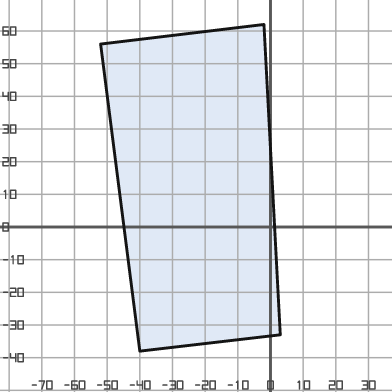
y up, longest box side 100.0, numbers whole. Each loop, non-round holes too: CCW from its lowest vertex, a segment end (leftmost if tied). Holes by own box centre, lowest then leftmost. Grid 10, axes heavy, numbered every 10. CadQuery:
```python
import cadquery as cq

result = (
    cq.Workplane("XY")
    .moveTo(-40.0, -38.0)
    .lineTo(3.0, -33.0)
    .lineTo(-2.0, 62.0)
    .lineTo(-52.0, 56.0)
    .close()
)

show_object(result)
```